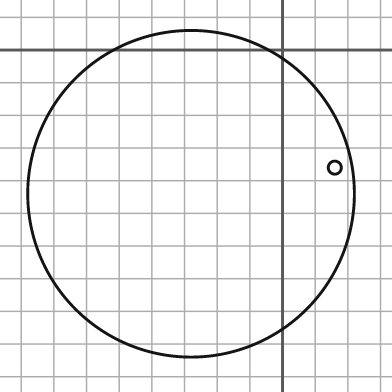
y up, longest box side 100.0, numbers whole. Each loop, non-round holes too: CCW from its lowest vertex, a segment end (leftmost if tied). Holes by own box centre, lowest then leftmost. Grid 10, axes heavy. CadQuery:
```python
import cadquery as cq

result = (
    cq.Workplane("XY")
    .moveTo(-28.0, -44.0)
    .circle(50.0)
    .moveTo(16.0, -36.0)
    .circle(2.0)
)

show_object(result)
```